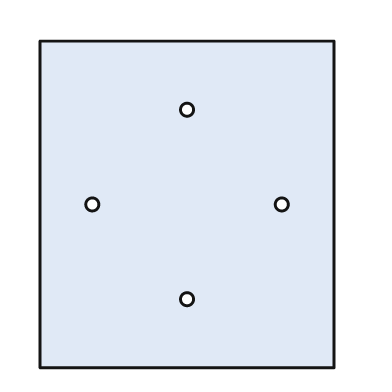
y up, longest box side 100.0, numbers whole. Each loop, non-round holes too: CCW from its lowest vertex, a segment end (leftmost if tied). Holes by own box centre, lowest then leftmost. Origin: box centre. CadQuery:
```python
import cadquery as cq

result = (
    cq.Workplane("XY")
    .moveTo(-45.0, -50.0)
    .lineTo(45.0, -50.0)
    .lineTo(45.0, 50.0)
    .lineTo(-45.0, 50.0)
    .close()
    .moveTo(0.0, -29.0)
    .circle(2.0)
    .moveTo(-29.0, 0.0)
    .circle(2.0)
    .moveTo(29.0, 0.0)
    .circle(2.0)
    .moveTo(0.0, 29.0)
    .circle(2.0)
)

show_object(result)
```